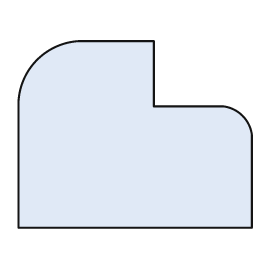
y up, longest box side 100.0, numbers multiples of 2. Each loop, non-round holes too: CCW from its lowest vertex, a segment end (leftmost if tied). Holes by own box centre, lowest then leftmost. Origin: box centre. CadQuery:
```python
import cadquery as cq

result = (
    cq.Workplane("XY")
    .moveTo(-50.0, -40.0)
    .lineTo(50.0, -40.0)
    .lineTo(50.0, 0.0)
    .threePointArc((46.0, 8.0), (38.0, 12.0))
    .lineTo(8.0, 12.0)
    .lineTo(8.0, 40.0)
    .lineTo(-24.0, 40.0)
    .threePointArc((-42.0, 32.0), (-50.0, 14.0))
    .close()
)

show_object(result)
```